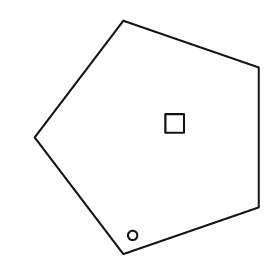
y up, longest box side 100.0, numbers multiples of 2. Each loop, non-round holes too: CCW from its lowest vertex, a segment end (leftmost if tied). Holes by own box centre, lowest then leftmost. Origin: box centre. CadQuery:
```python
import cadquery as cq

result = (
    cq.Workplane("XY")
    .moveTo(-10.0, -50.0)
    .lineTo(48.0, -30.0)
    .lineTo(48.0, 30.0)
    .lineTo(-10.0, 50.0)
    .lineTo(-48.0, 0.0)
    .close()
    .moveTo(-6.0, -42.0)
    .circle(2.0)
    .moveTo(8.0, 2.0)
    .lineTo(16.0, 2.0)
    .lineTo(16.0, 10.0)
    .lineTo(8.0, 10.0)
    .close()
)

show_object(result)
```